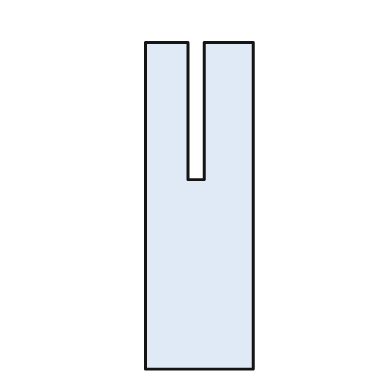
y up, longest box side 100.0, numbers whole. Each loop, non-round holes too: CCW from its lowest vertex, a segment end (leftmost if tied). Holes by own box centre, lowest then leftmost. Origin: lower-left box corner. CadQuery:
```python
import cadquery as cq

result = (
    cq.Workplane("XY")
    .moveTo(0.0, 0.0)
    .lineTo(33.0, 0.0)
    .lineTo(33.0, 100.0)
    .lineTo(18.0, 100.0)
    .lineTo(18.0, 58.0)
    .lineTo(13.0, 58.0)
    .lineTo(13.0, 100.0)
    .lineTo(0.0, 100.0)
    .close()
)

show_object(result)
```